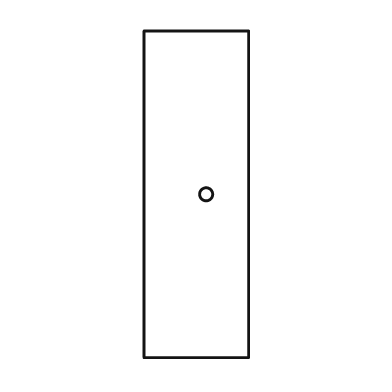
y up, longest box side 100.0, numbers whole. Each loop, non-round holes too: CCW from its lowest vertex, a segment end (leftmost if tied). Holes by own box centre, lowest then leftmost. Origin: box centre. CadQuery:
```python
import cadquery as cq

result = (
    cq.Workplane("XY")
    .moveTo(-16.0, -50.0)
    .lineTo(16.0, -50.0)
    .lineTo(16.0, 50.0)
    .lineTo(-16.0, 50.0)
    .close()
    .moveTo(3.0, 0.0)
    .circle(2.0)
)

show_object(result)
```